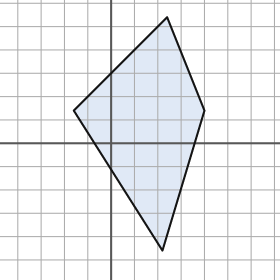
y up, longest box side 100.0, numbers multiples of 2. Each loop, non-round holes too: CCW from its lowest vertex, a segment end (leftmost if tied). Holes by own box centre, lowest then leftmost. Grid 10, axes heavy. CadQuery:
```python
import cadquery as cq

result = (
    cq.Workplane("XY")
    .moveTo(22.0, -46.0)
    .lineTo(40.0, 14.0)
    .lineTo(24.0, 54.0)
    .lineTo(-16.0, 14.0)
    .close()
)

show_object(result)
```